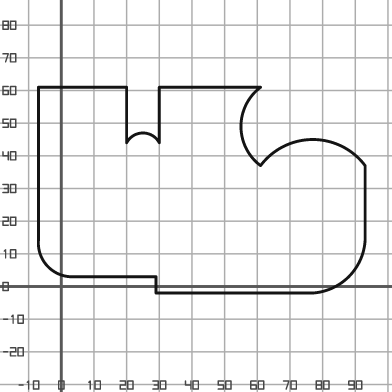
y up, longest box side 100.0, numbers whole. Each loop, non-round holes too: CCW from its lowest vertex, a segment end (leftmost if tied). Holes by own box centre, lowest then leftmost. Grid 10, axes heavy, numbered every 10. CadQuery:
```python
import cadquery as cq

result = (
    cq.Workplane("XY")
    .moveTo(29.0, -2.0)
    .lineTo(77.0, -2.0)
    .threePointArc((88.0, 3.0), (93.0, 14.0))
    .lineTo(93.0, 37.0)
    .threePointArc((77.0, 45.0), (61.0, 37.0))
    .threePointArc((55.0, 49.0), (61.0, 61.0))
    .lineTo(30.0, 61.0)
    .lineTo(30.0, 44.0)
    .threePointArc((25.0, 47.0), (20.0, 44.0))
    .lineTo(20.0, 61.0)
    .lineTo(-7.0, 61.0)
    .lineTo(-7.0, 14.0)
    .threePointArc((-4.0, 6.0), (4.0, 3.0))
    .lineTo(29.0, 3.0)
    .close()
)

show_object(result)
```